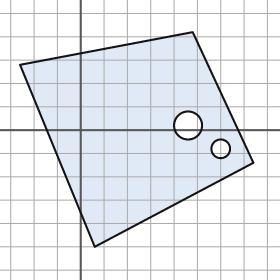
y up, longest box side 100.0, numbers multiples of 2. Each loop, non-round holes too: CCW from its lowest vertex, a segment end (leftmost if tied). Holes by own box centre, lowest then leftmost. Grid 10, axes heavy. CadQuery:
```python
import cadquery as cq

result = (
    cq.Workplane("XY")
    .moveTo(6.0, -50.0)
    .lineTo(74.0, -14.0)
    .lineTo(48.0, 42.0)
    .lineTo(-26.0, 28.0)
    .close()
    .moveTo(60.0, -8.0)
    .circle(4.0)
    .moveTo(46.0, 2.0)
    .circle(6.0)
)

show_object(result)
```